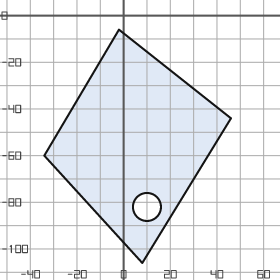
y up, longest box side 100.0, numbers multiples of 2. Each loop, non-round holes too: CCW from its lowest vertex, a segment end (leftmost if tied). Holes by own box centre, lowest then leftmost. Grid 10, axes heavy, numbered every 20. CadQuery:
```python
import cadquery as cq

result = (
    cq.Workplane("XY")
    .moveTo(8.0, -106.0)
    .lineTo(46.0, -44.0)
    .lineTo(-2.0, -6.0)
    .lineTo(-34.0, -60.0)
    .close()
    .moveTo(10.0, -82.0)
    .circle(6.0)
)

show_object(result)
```